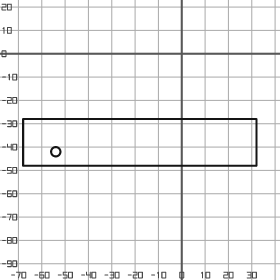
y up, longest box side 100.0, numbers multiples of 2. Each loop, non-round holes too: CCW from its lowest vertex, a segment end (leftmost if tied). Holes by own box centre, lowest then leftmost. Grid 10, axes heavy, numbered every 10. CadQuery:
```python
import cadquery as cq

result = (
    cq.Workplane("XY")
    .moveTo(-68.0, -48.0)
    .lineTo(32.0, -48.0)
    .lineTo(32.0, -28.0)
    .lineTo(-68.0, -28.0)
    .close()
    .moveTo(-54.0, -42.0)
    .circle(2.0)
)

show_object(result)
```